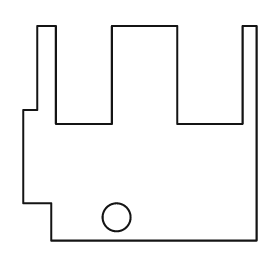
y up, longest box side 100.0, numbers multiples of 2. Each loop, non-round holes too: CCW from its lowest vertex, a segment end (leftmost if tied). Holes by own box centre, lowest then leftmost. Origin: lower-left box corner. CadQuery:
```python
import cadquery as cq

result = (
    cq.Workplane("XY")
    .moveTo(12.0, 0.0)
    .lineTo(100.0, 0.0)
    .lineTo(100.0, 92.0)
    .lineTo(94.0, 92.0)
    .lineTo(94.0, 50.0)
    .lineTo(66.0, 50.0)
    .lineTo(66.0, 92.0)
    .lineTo(38.0, 92.0)
    .lineTo(38.0, 50.0)
    .lineTo(14.0, 50.0)
    .lineTo(14.0, 92.0)
    .lineTo(6.0, 92.0)
    .lineTo(6.0, 56.0)
    .lineTo(0.0, 56.0)
    .lineTo(0.0, 16.0)
    .lineTo(12.0, 16.0)
    .close()
    .moveTo(40.0, 10.0)
    .circle(6.0)
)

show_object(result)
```